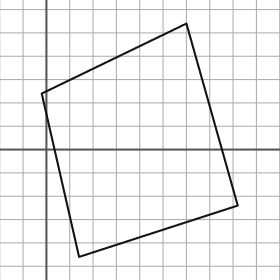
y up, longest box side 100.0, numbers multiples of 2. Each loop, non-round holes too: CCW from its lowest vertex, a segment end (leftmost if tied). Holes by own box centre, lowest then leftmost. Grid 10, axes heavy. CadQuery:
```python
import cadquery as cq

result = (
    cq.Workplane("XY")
    .moveTo(14.0, -46.0)
    .lineTo(82.0, -24.0)
    .lineTo(60.0, 54.0)
    .lineTo(-2.0, 24.0)
    .close()
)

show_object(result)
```